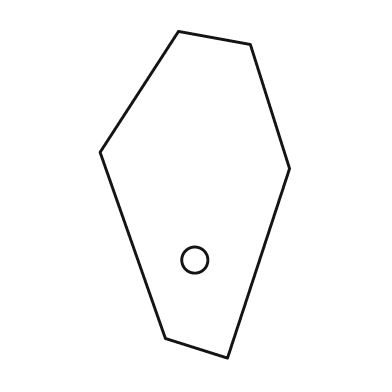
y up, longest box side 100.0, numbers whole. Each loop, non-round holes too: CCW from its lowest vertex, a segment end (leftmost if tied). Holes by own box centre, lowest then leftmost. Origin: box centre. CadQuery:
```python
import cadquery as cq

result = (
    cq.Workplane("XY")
    .moveTo(10.0, -50.0)
    .lineTo(29.0, 8.0)
    .lineTo(17.0, 46.0)
    .lineTo(-5.0, 50.0)
    .lineTo(-29.0, 13.0)
    .lineTo(-9.0, -44.0)
    .close()
    .moveTo(0.0, -20.0)
    .circle(4.0)
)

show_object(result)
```